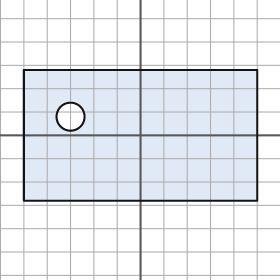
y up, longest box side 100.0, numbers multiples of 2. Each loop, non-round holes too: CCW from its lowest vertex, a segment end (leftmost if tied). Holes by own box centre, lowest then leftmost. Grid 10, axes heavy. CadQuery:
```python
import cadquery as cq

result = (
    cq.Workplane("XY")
    .moveTo(-50.0, -28.0)
    .lineTo(50.0, -28.0)
    .lineTo(50.0, 28.0)
    .lineTo(-50.0, 28.0)
    .close()
    .moveTo(-30.0, 8.0)
    .circle(6.0)
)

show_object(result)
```